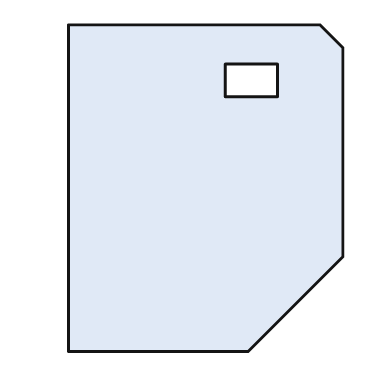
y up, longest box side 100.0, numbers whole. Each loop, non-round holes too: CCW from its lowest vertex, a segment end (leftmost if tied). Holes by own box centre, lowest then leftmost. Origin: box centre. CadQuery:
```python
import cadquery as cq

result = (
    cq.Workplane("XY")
    .moveTo(-42.0, -50.0)
    .lineTo(13.0, -50.0)
    .lineTo(42.0, -21.0)
    .lineTo(42.0, 43.0)
    .lineTo(35.0, 50.0)
    .lineTo(-42.0, 50.0)
    .close()
    .moveTo(6.0, 28.0)
    .lineTo(22.0, 28.0)
    .lineTo(22.0, 38.0)
    .lineTo(6.0, 38.0)
    .close()
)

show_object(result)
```